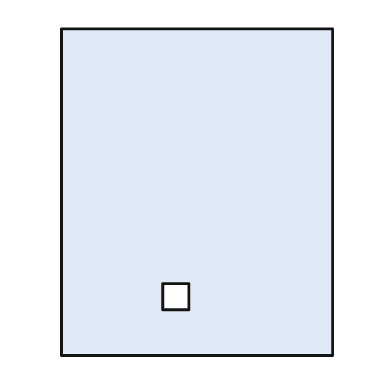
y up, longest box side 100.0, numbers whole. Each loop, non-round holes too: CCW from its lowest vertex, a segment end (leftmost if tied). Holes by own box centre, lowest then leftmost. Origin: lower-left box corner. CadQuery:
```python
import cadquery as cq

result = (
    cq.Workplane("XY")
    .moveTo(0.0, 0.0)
    .lineTo(83.0, 0.0)
    .lineTo(83.0, 100.0)
    .lineTo(0.0, 100.0)
    .close()
    .moveTo(31.0, 14.0)
    .lineTo(39.0, 14.0)
    .lineTo(39.0, 22.0)
    .lineTo(31.0, 22.0)
    .close()
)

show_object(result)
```